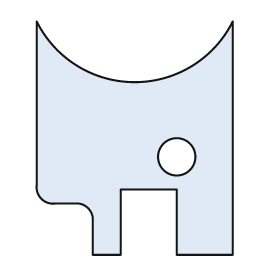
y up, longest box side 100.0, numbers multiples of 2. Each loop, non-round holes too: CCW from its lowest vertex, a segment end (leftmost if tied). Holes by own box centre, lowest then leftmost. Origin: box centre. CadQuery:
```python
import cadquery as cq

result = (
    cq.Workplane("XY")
    .moveTo(-18.0, -50.0)
    .lineTo(-6.0, -50.0)
    .lineTo(-6.0, -22.0)
    .lineTo(18.0, -22.0)
    .lineTo(18.0, -50.0)
    .lineTo(42.0, -50.0)
    .lineTo(42.0, 50.0)
    .threePointArc((0.0, 24.0), (-42.0, 50.0))
    .lineTo(-42.0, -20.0)
    .threePointArc((-40.0, -26.0), (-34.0, -28.0))
    .lineTo(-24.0, -28.0)
    .threePointArc((-20.0, -30.0), (-18.0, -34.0))
    .close()
    .moveTo(18.0, -8.0)
    .circle(8.0)
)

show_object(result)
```